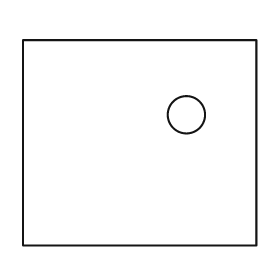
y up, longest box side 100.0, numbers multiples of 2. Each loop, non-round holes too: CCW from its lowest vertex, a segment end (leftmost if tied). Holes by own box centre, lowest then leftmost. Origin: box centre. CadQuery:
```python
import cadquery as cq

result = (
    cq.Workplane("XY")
    .moveTo(-50.0, -44.0)
    .lineTo(50.0, -44.0)
    .lineTo(50.0, 44.0)
    .lineTo(-50.0, 44.0)
    .close()
    .moveTo(20.0, 12.0)
    .circle(8.0)
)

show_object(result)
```